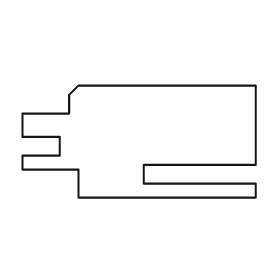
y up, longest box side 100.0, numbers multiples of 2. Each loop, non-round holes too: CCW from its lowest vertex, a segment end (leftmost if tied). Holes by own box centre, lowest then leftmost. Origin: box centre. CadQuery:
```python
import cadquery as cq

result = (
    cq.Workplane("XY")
    .moveTo(-26.0, -24.0)
    .lineTo(50.0, -24.0)
    .lineTo(50.0, -18.0)
    .lineTo(2.0, -18.0)
    .lineTo(2.0, -10.0)
    .lineTo(50.0, -10.0)
    .lineTo(50.0, 24.0)
    .lineTo(-26.0, 24.0)
    .lineTo(-30.0, 20.0)
    .lineTo(-30.0, 12.0)
    .lineTo(-50.0, 12.0)
    .lineTo(-50.0, 2.0)
    .lineTo(-34.0, 2.0)
    .lineTo(-34.0, -6.0)
    .lineTo(-50.0, -6.0)
    .lineTo(-50.0, -12.0)
    .lineTo(-26.0, -12.0)
    .close()
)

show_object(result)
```